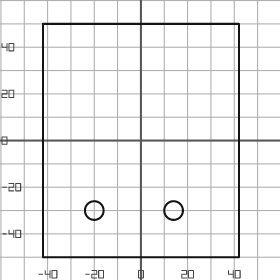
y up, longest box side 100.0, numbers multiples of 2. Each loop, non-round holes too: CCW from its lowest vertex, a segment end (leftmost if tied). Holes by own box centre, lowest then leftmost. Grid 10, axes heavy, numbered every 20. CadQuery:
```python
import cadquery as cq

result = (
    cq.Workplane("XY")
    .moveTo(-42.0, -50.0)
    .lineTo(42.0, -50.0)
    .lineTo(42.0, 50.0)
    .lineTo(-42.0, 50.0)
    .close()
    .moveTo(-20.0, -30.0)
    .circle(4.0)
    .moveTo(14.0, -30.0)
    .circle(4.0)
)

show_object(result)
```